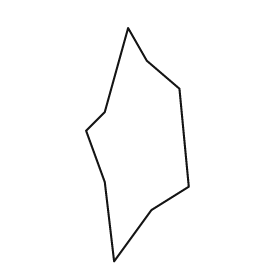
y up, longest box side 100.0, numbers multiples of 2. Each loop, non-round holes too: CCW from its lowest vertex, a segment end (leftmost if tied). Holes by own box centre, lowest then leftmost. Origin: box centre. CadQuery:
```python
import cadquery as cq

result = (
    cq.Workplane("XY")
    .moveTo(-10.0, -50.0)
    .lineTo(6.0, -28.0)
    .lineTo(22.0, -18.0)
    .lineTo(18.0, 24.0)
    .lineTo(4.0, 36.0)
    .lineTo(-4.0, 50.0)
    .lineTo(-14.0, 14.0)
    .lineTo(-22.0, 6.0)
    .lineTo(-14.0, -16.0)
    .close()
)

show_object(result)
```